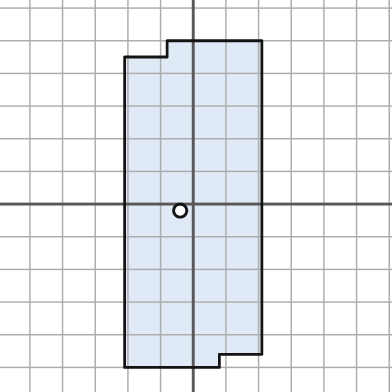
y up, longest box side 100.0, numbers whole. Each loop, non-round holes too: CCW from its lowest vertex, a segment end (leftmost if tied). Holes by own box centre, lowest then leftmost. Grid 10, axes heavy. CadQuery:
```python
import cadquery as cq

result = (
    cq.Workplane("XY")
    .moveTo(-21.0, -50.0)
    .lineTo(8.0, -50.0)
    .lineTo(8.0, -46.0)
    .lineTo(21.0, -46.0)
    .lineTo(21.0, 50.0)
    .lineTo(-8.0, 50.0)
    .lineTo(-8.0, 45.0)
    .lineTo(-21.0, 45.0)
    .close()
    .moveTo(-4.0, -2.0)
    .circle(2.0)
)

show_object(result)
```